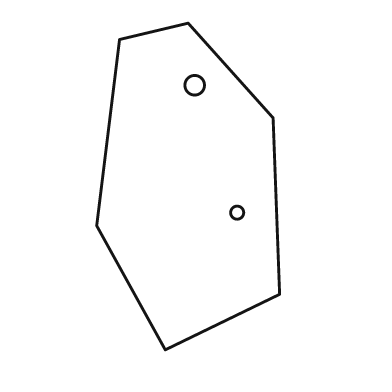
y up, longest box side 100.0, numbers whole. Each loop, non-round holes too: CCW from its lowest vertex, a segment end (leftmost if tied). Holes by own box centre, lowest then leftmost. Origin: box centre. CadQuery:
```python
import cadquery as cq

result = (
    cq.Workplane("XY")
    .moveTo(-7.0, -50.0)
    .lineTo(28.0, -33.0)
    .lineTo(26.0, 21.0)
    .lineTo(0.0, 50.0)
    .lineTo(-21.0, 45.0)
    .lineTo(-28.0, -12.0)
    .close()
    .moveTo(15.0, -8.0)
    .circle(2.0)
    .moveTo(2.0, 31.0)
    .circle(3.0)
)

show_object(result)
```